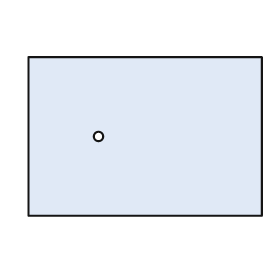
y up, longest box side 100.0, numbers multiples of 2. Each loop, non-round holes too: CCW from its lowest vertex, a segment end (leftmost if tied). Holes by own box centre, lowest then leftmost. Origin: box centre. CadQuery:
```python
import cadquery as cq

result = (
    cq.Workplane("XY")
    .moveTo(-50.0, -34.0)
    .lineTo(50.0, -34.0)
    .lineTo(50.0, 34.0)
    .lineTo(-50.0, 34.0)
    .close()
    .moveTo(-20.0, 0.0)
    .circle(2.0)
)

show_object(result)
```